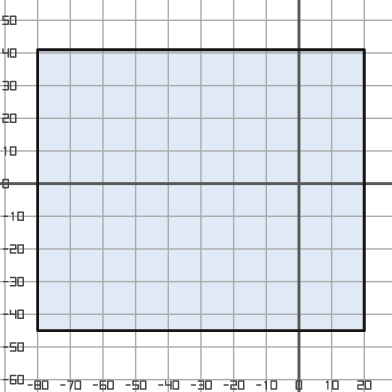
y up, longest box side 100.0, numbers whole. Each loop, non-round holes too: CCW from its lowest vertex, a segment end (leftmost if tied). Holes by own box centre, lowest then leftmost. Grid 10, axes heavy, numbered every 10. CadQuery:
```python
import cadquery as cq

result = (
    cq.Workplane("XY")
    .moveTo(-80.0, -45.0)
    .lineTo(20.0, -45.0)
    .lineTo(20.0, 41.0)
    .lineTo(-80.0, 41.0)
    .close()
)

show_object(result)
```